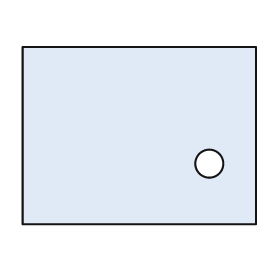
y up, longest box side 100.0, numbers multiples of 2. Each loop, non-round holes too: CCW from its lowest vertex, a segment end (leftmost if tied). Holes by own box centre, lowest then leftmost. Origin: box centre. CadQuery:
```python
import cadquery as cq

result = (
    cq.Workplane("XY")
    .moveTo(-50.0, -38.0)
    .lineTo(50.0, -38.0)
    .lineTo(50.0, 38.0)
    .lineTo(-50.0, 38.0)
    .close()
    .moveTo(30.0, -12.0)
    .circle(6.0)
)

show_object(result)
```